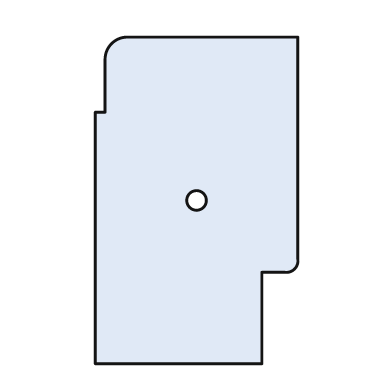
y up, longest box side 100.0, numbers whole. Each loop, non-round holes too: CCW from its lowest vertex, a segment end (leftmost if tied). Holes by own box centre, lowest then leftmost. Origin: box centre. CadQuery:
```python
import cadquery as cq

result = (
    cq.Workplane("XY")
    .moveTo(-31.0, -50.0)
    .lineTo(20.0, -50.0)
    .lineTo(20.0, -22.0)
    .lineTo(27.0, -22.0)
    .threePointArc((30.0, -21.0), (31.0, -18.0))
    .lineTo(31.0, 50.0)
    .lineTo(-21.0, 50.0)
    .threePointArc((-26.0, 48.0), (-28.0, 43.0))
    .lineTo(-28.0, 27.0)
    .lineTo(-31.0, 27.0)
    .close()
    .moveTo(0.0, 0.0)
    .circle(3.0)
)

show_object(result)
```